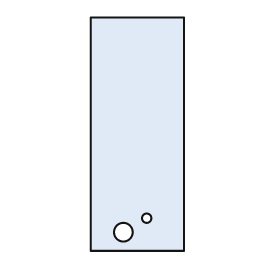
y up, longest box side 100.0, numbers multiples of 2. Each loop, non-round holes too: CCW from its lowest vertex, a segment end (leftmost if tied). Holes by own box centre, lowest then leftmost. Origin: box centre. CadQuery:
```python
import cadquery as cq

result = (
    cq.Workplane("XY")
    .moveTo(-20.0, -50.0)
    .lineTo(20.0, -50.0)
    .lineTo(20.0, 50.0)
    .lineTo(-20.0, 50.0)
    .close()
    .moveTo(-6.0, -42.0)
    .circle(4.0)
    .moveTo(4.0, -36.0)
    .circle(2.0)
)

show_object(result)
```